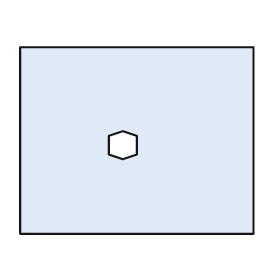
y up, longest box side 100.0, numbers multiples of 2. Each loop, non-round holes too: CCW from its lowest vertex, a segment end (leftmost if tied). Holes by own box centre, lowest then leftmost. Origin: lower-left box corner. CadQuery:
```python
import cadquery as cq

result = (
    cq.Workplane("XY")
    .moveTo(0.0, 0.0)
    .lineTo(100.0, 0.0)
    .lineTo(100.0, 80.0)
    .lineTo(0.0, 80.0)
    .close()
    .moveTo(44.0, 32.0)
    .lineTo(50.0, 34.0)
    .lineTo(50.0, 42.0)
    .lineTo(44.0, 44.0)
    .lineTo(38.0, 42.0)
    .lineTo(38.0, 34.0)
    .close()
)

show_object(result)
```